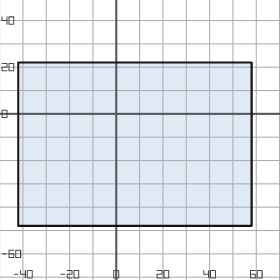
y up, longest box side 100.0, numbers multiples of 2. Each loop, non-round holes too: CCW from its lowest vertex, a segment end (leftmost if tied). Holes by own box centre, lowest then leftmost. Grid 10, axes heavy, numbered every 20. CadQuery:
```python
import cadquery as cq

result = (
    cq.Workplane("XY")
    .moveTo(-42.0, -48.0)
    .lineTo(58.0, -48.0)
    .lineTo(58.0, 22.0)
    .lineTo(-42.0, 22.0)
    .close()
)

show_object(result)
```